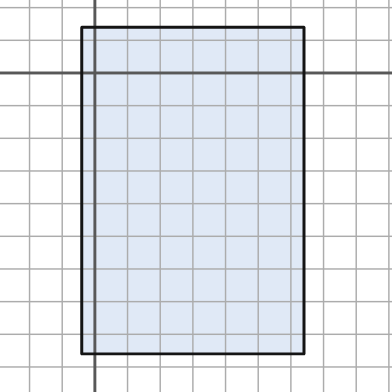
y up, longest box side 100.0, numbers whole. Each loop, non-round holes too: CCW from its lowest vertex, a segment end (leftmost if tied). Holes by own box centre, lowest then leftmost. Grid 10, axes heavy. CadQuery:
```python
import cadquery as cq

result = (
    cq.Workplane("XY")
    .moveTo(-4.0, -86.0)
    .lineTo(64.0, -86.0)
    .lineTo(64.0, 14.0)
    .lineTo(-4.0, 14.0)
    .close()
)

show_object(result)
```